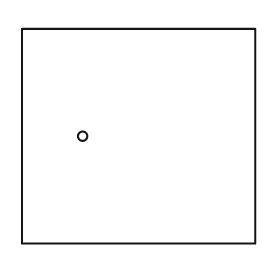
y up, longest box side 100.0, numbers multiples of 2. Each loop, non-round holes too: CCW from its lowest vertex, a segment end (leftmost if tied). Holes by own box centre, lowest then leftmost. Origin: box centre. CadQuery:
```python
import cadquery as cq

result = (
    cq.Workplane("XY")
    .moveTo(-50.0, -46.0)
    .lineTo(50.0, -46.0)
    .lineTo(50.0, 46.0)
    .lineTo(-50.0, 46.0)
    .close()
    .moveTo(-24.0, 0.0)
    .circle(2.0)
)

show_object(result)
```